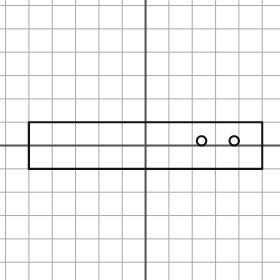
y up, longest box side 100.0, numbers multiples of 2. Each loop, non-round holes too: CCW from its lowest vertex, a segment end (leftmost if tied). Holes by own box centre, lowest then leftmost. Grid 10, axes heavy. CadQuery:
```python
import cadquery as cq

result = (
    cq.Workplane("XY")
    .moveTo(-50.0, -10.0)
    .lineTo(50.0, -10.0)
    .lineTo(50.0, 10.0)
    .lineTo(-50.0, 10.0)
    .close()
    .moveTo(24.0, 2.0)
    .circle(2.0)
    .moveTo(38.0, 2.0)
    .circle(2.0)
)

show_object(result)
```